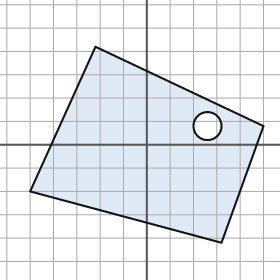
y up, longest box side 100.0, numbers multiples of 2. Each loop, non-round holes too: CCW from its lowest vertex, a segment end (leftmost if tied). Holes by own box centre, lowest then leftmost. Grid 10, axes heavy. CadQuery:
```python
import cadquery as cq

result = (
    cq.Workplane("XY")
    .moveTo(32.0, -42.0)
    .lineTo(50.0, 8.0)
    .lineTo(-22.0, 42.0)
    .lineTo(-50.0, -20.0)
    .close()
    .moveTo(26.0, 8.0)
    .circle(6.0)
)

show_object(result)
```